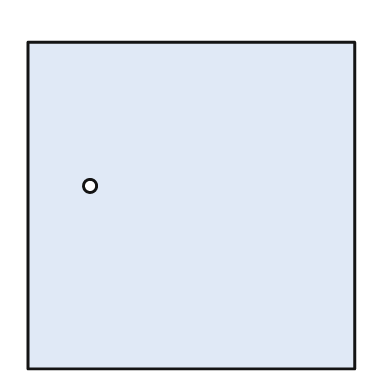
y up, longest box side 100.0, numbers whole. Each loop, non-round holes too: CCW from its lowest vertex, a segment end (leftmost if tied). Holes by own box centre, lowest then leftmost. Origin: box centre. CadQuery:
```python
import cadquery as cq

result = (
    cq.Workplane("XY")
    .moveTo(-50.0, -50.0)
    .lineTo(50.0, -50.0)
    .lineTo(50.0, 50.0)
    .lineTo(-50.0, 50.0)
    .close()
    .moveTo(-31.0, 6.0)
    .circle(2.0)
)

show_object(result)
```